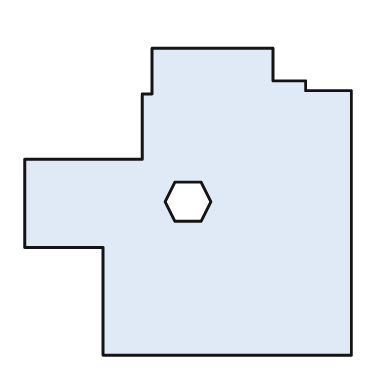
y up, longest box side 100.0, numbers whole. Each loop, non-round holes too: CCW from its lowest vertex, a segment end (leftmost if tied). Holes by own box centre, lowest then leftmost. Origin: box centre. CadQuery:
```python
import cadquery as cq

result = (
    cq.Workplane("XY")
    .moveTo(-26.0, -47.0)
    .lineTo(50.0, -47.0)
    .lineTo(50.0, 34.0)
    .lineTo(36.0, 34.0)
    .lineTo(36.0, 37.0)
    .lineTo(26.0, 37.0)
    .lineTo(26.0, 47.0)
    .lineTo(-11.0, 47.0)
    .lineTo(-11.0, 33.0)
    .lineTo(-14.0, 33.0)
    .lineTo(-14.0, 13.0)
    .lineTo(-50.0, 13.0)
    .lineTo(-50.0, -14.0)
    .lineTo(-26.0, -14.0)
    .close()
    .moveTo(-4.0, -6.0)
    .lineTo(4.0, -6.0)
    .lineTo(7.0, 0.0)
    .lineTo(4.0, 6.0)
    .lineTo(-4.0, 6.0)
    .lineTo(-7.0, 0.0)
    .close()
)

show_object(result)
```